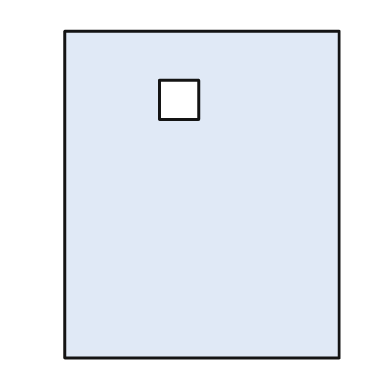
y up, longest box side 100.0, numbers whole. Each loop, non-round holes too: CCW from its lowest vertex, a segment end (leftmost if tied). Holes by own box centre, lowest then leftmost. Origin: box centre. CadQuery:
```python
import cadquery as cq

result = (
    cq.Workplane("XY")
    .moveTo(-42.0, -50.0)
    .lineTo(42.0, -50.0)
    .lineTo(42.0, 50.0)
    .lineTo(-42.0, 50.0)
    .close()
    .moveTo(-13.0, 23.0)
    .lineTo(-1.0, 23.0)
    .lineTo(-1.0, 35.0)
    .lineTo(-13.0, 35.0)
    .close()
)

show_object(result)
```